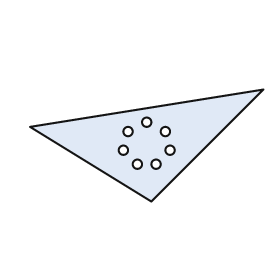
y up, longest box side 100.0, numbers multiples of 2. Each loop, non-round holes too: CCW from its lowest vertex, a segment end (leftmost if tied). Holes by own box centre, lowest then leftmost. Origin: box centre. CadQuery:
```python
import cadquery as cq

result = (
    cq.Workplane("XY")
    .moveTo(2.0, -24.0)
    .lineTo(50.0, 24.0)
    .lineTo(-50.0, 8.0)
    .close()
    .moveTo(-4.0, -8.0)
    .circle(2.0)
    .moveTo(4.0, -8.0)
    .circle(2.0)
    .moveTo(-10.0, -2.0)
    .circle(2.0)
    .moveTo(10.0, -2.0)
    .circle(2.0)
    .moveTo(-8.0, 6.0)
    .circle(2.0)
    .moveTo(8.0, 6.0)
    .circle(2.0)
    .moveTo(0.0, 10.0)
    .circle(2.0)
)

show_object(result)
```